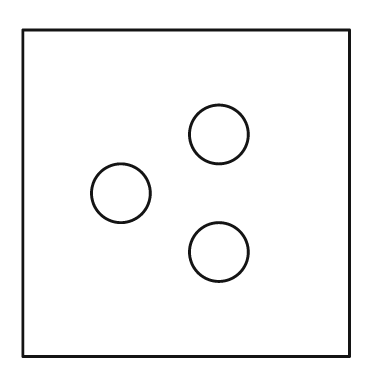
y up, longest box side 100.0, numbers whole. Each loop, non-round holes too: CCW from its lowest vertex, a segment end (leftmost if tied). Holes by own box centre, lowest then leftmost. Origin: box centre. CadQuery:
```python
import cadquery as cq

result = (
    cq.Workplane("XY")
    .moveTo(-50.0, -50.0)
    .lineTo(50.0, -50.0)
    .lineTo(50.0, 50.0)
    .lineTo(-50.0, 50.0)
    .close()
    .moveTo(10.0, -18.0)
    .circle(9.0)
    .moveTo(-20.0, 0.0)
    .circle(9.0)
    .moveTo(10.0, 18.0)
    .circle(9.0)
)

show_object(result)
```